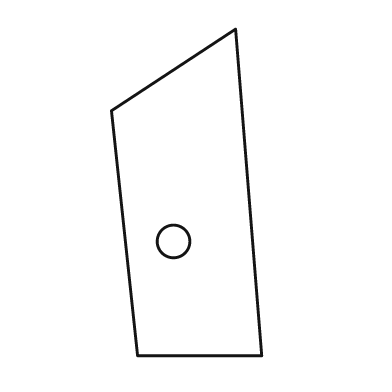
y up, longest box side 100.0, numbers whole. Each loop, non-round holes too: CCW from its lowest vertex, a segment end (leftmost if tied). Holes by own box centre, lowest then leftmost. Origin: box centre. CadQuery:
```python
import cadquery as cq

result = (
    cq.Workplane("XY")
    .moveTo(-15.0, -50.0)
    .lineTo(23.0, -50.0)
    .lineTo(15.0, 50.0)
    .lineTo(-23.0, 25.0)
    .close()
    .moveTo(-4.0, -15.0)
    .circle(5.0)
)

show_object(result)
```